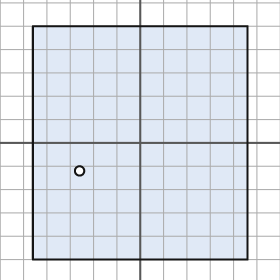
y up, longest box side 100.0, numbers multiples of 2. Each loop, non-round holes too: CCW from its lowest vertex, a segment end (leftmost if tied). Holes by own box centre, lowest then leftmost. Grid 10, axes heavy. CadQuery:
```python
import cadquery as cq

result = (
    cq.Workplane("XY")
    .moveTo(-46.0, -50.0)
    .lineTo(46.0, -50.0)
    .lineTo(46.0, 50.0)
    .lineTo(-46.0, 50.0)
    .close()
    .moveTo(-26.0, -12.0)
    .circle(2.0)
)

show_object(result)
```